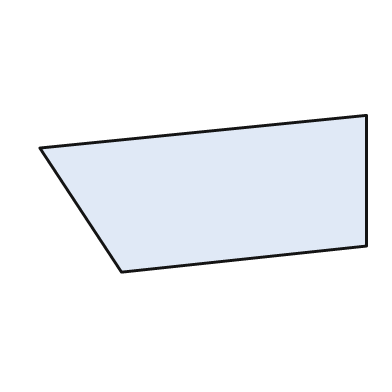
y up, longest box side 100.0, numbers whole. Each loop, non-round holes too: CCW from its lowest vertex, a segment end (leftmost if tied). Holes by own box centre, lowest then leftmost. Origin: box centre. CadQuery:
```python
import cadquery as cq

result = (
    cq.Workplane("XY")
    .moveTo(-25.0, -24.0)
    .lineTo(50.0, -16.0)
    .lineTo(50.0, 24.0)
    .lineTo(-50.0, 14.0)
    .close()
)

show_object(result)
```